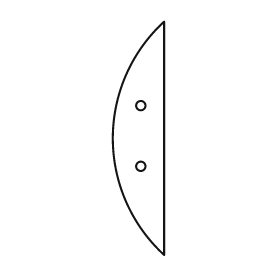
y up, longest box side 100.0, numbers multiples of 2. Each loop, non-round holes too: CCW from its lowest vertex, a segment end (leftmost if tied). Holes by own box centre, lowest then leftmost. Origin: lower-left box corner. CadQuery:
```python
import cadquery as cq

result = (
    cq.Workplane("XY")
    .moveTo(22.0, 0.0)
    .lineTo(22.0, 100.0)
    .threePointArc((0.0, 50.0), (22.0, 0.0))
    .close()
    .moveTo(12.0, 38.0)
    .circle(2.0)
    .moveTo(12.0, 64.0)
    .circle(2.0)
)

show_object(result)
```